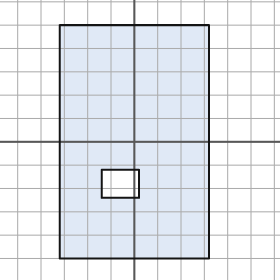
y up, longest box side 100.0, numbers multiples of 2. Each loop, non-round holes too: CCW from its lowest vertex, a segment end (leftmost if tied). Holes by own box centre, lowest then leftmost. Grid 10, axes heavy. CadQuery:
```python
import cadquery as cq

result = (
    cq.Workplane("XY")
    .moveTo(-32.0, -50.0)
    .lineTo(32.0, -50.0)
    .lineTo(32.0, 50.0)
    .lineTo(-32.0, 50.0)
    .close()
    .moveTo(-14.0, -24.0)
    .lineTo(2.0, -24.0)
    .lineTo(2.0, -12.0)
    .lineTo(-14.0, -12.0)
    .close()
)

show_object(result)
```